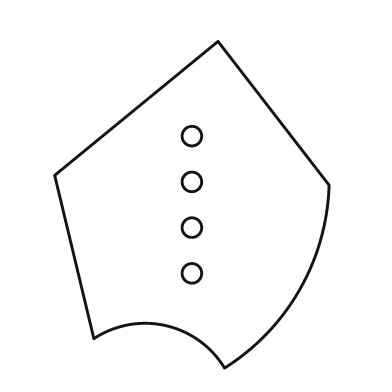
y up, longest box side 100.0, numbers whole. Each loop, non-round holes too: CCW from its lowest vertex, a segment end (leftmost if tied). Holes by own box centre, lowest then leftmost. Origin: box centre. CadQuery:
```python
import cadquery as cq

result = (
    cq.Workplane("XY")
    .moveTo(10.0, -50.0)
    .threePointArc((33.0, -26.0), (42.0, 6.0))
    .lineTo(8.0, 50.0)
    .lineTo(-42.0, 9.0)
    .lineTo(-30.0, -41.0)
    .threePointArc((-8.0, -37.0), (10.0, -50.0))
    .close()
    .moveTo(0.0, -21.0)
    .circle(3.0)
    .moveTo(0.0, -7.0)
    .circle(3.0)
    .moveTo(0.0, 7.0)
    .circle(3.0)
    .moveTo(0.0, 21.0)
    .circle(3.0)
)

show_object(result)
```